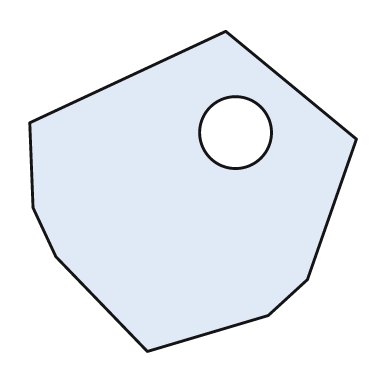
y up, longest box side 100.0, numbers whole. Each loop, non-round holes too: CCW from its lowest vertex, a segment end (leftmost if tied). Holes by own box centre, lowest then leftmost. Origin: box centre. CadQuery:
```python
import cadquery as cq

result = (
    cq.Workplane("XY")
    .moveTo(-14.0, -49.0)
    .lineTo(23.0, -38.0)
    .lineTo(35.0, -27.0)
    .lineTo(50.0, 16.0)
    .lineTo(10.0, 49.0)
    .lineTo(-50.0, 21.0)
    .lineTo(-49.0, -5.0)
    .lineTo(-42.0, -20.0)
    .close()
    .moveTo(13.0, 18.0)
    .circle(11.0)
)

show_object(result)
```